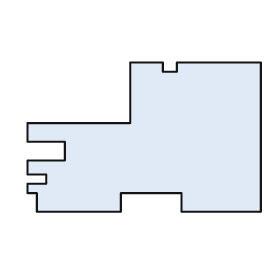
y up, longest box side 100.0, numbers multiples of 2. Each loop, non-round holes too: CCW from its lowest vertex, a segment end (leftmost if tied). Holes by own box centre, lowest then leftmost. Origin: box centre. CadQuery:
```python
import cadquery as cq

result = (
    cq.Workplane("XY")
    .moveTo(-46.0, -32.0)
    .lineTo(-10.0, -32.0)
    .lineTo(-10.0, -24.0)
    .lineTo(16.0, -24.0)
    .lineTo(16.0, -32.0)
    .lineTo(50.0, -32.0)
    .lineTo(50.0, 32.0)
    .lineTo(14.0, 32.0)
    .lineTo(14.0, 28.0)
    .lineTo(8.0, 28.0)
    .lineTo(8.0, 32.0)
    .lineTo(-6.0, 32.0)
    .lineTo(-6.0, 6.0)
    .lineTo(-50.0, 6.0)
    .lineTo(-50.0, -2.0)
    .lineTo(-34.0, -2.0)
    .lineTo(-34.0, -10.0)
    .lineTo(-50.0, -10.0)
    .lineTo(-50.0, -16.0)
    .lineTo(-42.0, -16.0)
    .lineTo(-42.0, -20.0)
    .lineTo(-50.0, -20.0)
    .lineTo(-50.0, -24.0)
    .lineTo(-46.0, -24.0)
    .close()
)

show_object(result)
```